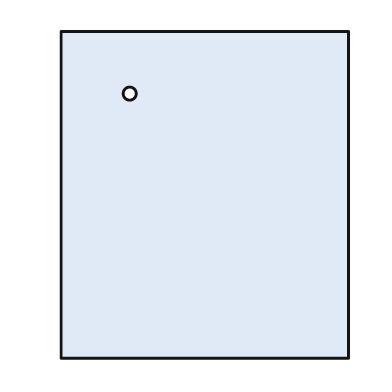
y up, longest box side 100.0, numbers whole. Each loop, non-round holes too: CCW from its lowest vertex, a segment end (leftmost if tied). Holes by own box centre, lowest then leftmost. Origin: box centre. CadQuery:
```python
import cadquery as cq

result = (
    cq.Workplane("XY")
    .moveTo(-44.0, -50.0)
    .lineTo(44.0, -50.0)
    .lineTo(44.0, 50.0)
    .lineTo(-44.0, 50.0)
    .close()
    .moveTo(-23.0, 31.0)
    .circle(2.0)
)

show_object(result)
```